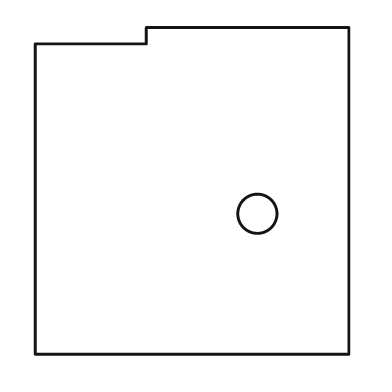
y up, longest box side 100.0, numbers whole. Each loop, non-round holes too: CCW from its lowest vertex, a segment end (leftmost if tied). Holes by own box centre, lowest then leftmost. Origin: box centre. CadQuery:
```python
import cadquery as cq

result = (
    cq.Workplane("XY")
    .moveTo(-48.0, -50.0)
    .lineTo(48.0, -50.0)
    .lineTo(48.0, 50.0)
    .lineTo(-14.0, 50.0)
    .lineTo(-14.0, 45.0)
    .lineTo(-48.0, 45.0)
    .close()
    .moveTo(20.0, -7.0)
    .circle(6.0)
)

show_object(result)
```